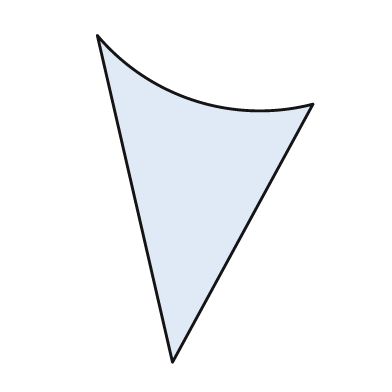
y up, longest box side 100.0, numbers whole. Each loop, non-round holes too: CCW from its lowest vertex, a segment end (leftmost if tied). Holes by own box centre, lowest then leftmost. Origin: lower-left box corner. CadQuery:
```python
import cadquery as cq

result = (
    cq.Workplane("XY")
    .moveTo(23.0, 0.0)
    .lineTo(66.0, 79.0)
    .threePointArc((30.0, 80.0), (0.0, 100.0))
    .close()
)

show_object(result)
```